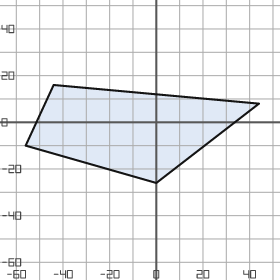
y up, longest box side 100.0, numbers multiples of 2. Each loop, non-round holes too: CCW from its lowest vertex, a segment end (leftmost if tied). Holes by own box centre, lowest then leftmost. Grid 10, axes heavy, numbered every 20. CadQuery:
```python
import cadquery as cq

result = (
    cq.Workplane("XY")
    .moveTo(0.0, -26.0)
    .lineTo(44.0, 8.0)
    .lineTo(-44.0, 16.0)
    .lineTo(-56.0, -10.0)
    .close()
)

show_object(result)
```